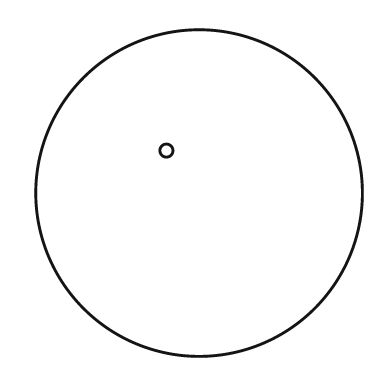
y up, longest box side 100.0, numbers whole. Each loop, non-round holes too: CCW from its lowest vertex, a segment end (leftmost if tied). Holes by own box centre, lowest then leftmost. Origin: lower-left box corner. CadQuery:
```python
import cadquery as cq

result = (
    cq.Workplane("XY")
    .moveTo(50.0, 50.0)
    .circle(50.0)
    .moveTo(40.0, 63.0)
    .circle(2.0)
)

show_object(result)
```